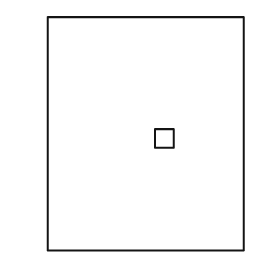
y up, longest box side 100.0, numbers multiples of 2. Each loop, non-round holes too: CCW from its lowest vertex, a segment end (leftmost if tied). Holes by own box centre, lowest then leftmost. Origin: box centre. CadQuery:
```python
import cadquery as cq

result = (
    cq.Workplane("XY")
    .moveTo(-42.0, -50.0)
    .lineTo(42.0, -50.0)
    .lineTo(42.0, 50.0)
    .lineTo(-42.0, 50.0)
    .close()
    .moveTo(4.0, -6.0)
    .lineTo(12.0, -6.0)
    .lineTo(12.0, 2.0)
    .lineTo(4.0, 2.0)
    .close()
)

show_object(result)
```